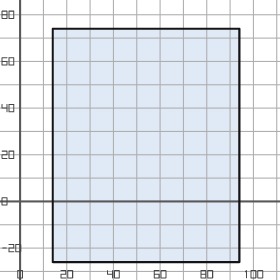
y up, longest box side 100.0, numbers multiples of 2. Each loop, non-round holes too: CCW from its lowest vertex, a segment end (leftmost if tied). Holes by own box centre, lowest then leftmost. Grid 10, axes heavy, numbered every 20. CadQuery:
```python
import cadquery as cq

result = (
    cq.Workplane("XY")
    .moveTo(14.0, -26.0)
    .lineTo(94.0, -26.0)
    .lineTo(94.0, 74.0)
    .lineTo(14.0, 74.0)
    .close()
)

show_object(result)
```